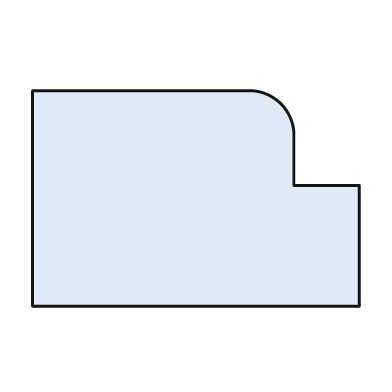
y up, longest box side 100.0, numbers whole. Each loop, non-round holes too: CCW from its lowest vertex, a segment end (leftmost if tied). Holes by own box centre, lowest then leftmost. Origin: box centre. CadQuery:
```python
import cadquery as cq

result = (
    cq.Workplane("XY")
    .moveTo(-50.0, -33.0)
    .lineTo(50.0, -33.0)
    .lineTo(50.0, 4.0)
    .lineTo(30.0, 4.0)
    .lineTo(30.0, 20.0)
    .threePointArc((26.0, 29.0), (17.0, 33.0))
    .lineTo(-50.0, 33.0)
    .close()
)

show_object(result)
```